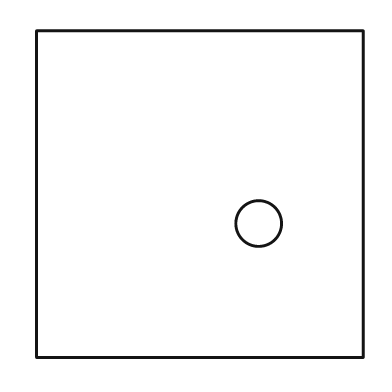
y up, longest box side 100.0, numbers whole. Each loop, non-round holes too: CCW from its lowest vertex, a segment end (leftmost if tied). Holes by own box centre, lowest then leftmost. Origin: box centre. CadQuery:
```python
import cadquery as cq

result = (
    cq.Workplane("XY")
    .moveTo(-50.0, -50.0)
    .lineTo(50.0, -50.0)
    .lineTo(50.0, 50.0)
    .lineTo(-50.0, 50.0)
    .close()
    .moveTo(18.0, -9.0)
    .circle(7.0)
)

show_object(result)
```